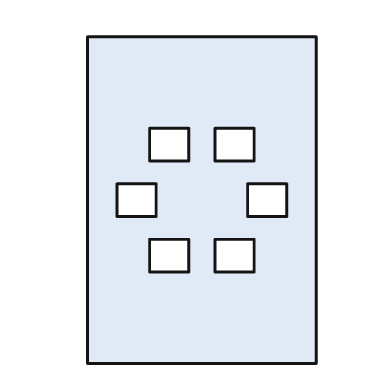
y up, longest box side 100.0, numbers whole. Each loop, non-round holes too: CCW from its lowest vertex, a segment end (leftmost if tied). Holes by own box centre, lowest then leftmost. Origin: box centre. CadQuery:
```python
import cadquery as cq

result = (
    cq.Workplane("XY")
    .moveTo(-35.0, -50.0)
    .lineTo(35.0, -50.0)
    .lineTo(35.0, 50.0)
    .lineTo(-35.0, 50.0)
    .close()
    .moveTo(-16.0, -22.0)
    .lineTo(-4.0, -22.0)
    .lineTo(-4.0, -12.0)
    .lineTo(-16.0, -12.0)
    .close()
    .moveTo(4.0, -22.0)
    .lineTo(16.0, -22.0)
    .lineTo(16.0, -12.0)
    .lineTo(4.0, -12.0)
    .close()
    .moveTo(-26.0, -5.0)
    .lineTo(-14.0, -5.0)
    .lineTo(-14.0, 5.0)
    .lineTo(-26.0, 5.0)
    .close()
    .moveTo(14.0, -5.0)
    .lineTo(26.0, -5.0)
    .lineTo(26.0, 5.0)
    .lineTo(14.0, 5.0)
    .close()
    .moveTo(-16.0, 12.0)
    .lineTo(-4.0, 12.0)
    .lineTo(-4.0, 22.0)
    .lineTo(-16.0, 22.0)
    .close()
    .moveTo(4.0, 12.0)
    .lineTo(16.0, 12.0)
    .lineTo(16.0, 22.0)
    .lineTo(4.0, 22.0)
    .close()
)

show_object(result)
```